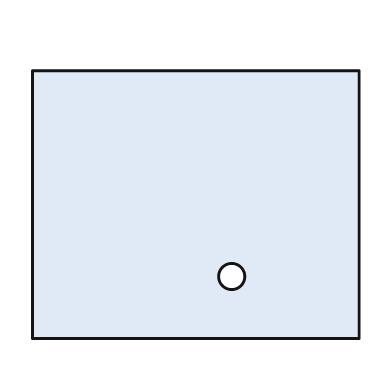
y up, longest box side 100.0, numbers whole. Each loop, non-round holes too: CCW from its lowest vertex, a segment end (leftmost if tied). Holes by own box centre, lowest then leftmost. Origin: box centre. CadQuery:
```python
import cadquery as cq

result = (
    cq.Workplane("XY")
    .moveTo(-50.0, -41.0)
    .lineTo(50.0, -41.0)
    .lineTo(50.0, 41.0)
    .lineTo(-50.0, 41.0)
    .close()
    .moveTo(11.0, -22.0)
    .circle(4.0)
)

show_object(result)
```